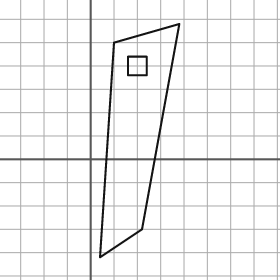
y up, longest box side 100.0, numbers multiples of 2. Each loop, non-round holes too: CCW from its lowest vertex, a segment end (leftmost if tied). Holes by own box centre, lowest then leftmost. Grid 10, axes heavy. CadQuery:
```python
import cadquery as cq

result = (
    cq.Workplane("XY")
    .moveTo(4.0, -42.0)
    .lineTo(22.0, -30.0)
    .lineTo(38.0, 58.0)
    .lineTo(10.0, 50.0)
    .close()
    .moveTo(16.0, 36.0)
    .lineTo(24.0, 36.0)
    .lineTo(24.0, 44.0)
    .lineTo(16.0, 44.0)
    .close()
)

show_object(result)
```